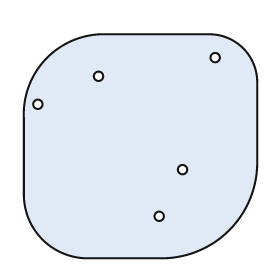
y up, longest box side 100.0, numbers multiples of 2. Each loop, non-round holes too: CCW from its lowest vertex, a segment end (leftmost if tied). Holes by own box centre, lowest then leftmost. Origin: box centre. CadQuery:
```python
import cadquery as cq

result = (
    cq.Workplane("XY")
    .moveTo(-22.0, -48.0)
    .lineTo(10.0, -48.0)
    .threePointArc((38.0, -36.0), (50.0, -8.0))
    .lineTo(50.0, 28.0)
    .threePointArc((44.0, 42.0), (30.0, 48.0))
    .lineTo(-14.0, 48.0)
    .threePointArc((-40.0, 38.0), (-50.0, 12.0))
    .lineTo(-50.0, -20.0)
    .threePointArc((-42.0, -40.0), (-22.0, -48.0))
    .close()
    .moveTo(8.0, -30.0)
    .circle(2.0)
    .moveTo(18.0, -10.0)
    .circle(2.0)
    .moveTo(-44.0, 18.0)
    .circle(2.0)
    .moveTo(-18.0, 30.0)
    .circle(2.0)
    .moveTo(32.0, 38.0)
    .circle(2.0)
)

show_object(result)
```